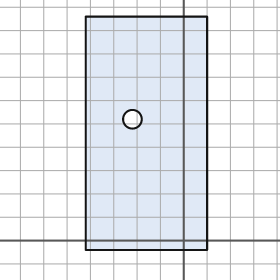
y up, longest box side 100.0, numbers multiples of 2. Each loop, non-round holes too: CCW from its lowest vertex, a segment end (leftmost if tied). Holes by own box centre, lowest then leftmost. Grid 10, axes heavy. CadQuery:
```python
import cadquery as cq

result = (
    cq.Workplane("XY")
    .moveTo(-42.0, -4.0)
    .lineTo(10.0, -4.0)
    .lineTo(10.0, 96.0)
    .lineTo(-42.0, 96.0)
    .close()
    .moveTo(-22.0, 52.0)
    .circle(4.0)
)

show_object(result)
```